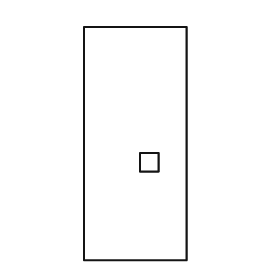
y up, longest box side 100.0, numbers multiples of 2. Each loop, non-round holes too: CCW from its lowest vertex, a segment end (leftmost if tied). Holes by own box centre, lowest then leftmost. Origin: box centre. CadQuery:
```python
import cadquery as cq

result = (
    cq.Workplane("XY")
    .moveTo(-22.0, -50.0)
    .lineTo(22.0, -50.0)
    .lineTo(22.0, 50.0)
    .lineTo(-22.0, 50.0)
    .close()
    .moveTo(2.0, -12.0)
    .lineTo(10.0, -12.0)
    .lineTo(10.0, -4.0)
    .lineTo(2.0, -4.0)
    .close()
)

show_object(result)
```